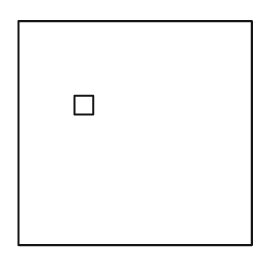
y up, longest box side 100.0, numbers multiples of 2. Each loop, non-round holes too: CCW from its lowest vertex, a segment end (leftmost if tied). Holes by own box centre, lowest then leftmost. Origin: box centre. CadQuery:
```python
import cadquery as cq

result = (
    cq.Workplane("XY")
    .moveTo(-50.0, -48.0)
    .lineTo(50.0, -48.0)
    .lineTo(50.0, 48.0)
    .lineTo(-50.0, 48.0)
    .close()
    .moveTo(-26.0, 8.0)
    .lineTo(-18.0, 8.0)
    .lineTo(-18.0, 16.0)
    .lineTo(-26.0, 16.0)
    .close()
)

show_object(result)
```